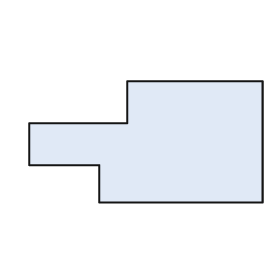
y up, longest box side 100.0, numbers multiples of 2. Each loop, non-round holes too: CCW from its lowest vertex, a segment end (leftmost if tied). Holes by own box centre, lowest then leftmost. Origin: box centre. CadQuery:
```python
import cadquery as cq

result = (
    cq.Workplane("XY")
    .moveTo(-20.0, -26.0)
    .lineTo(50.0, -26.0)
    .lineTo(50.0, 26.0)
    .lineTo(-8.0, 26.0)
    .lineTo(-8.0, 8.0)
    .lineTo(-50.0, 8.0)
    .lineTo(-50.0, -10.0)
    .lineTo(-20.0, -10.0)
    .close()
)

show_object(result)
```